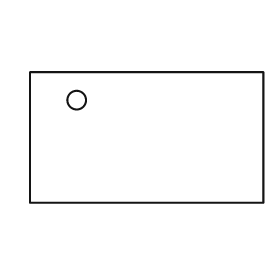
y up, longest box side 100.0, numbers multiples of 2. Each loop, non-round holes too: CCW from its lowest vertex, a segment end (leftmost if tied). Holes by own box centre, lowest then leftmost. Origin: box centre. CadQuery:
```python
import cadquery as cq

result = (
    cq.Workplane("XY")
    .moveTo(-50.0, -28.0)
    .lineTo(50.0, -28.0)
    .lineTo(50.0, 28.0)
    .lineTo(-50.0, 28.0)
    .close()
    .moveTo(-30.0, 16.0)
    .circle(4.0)
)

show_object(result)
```